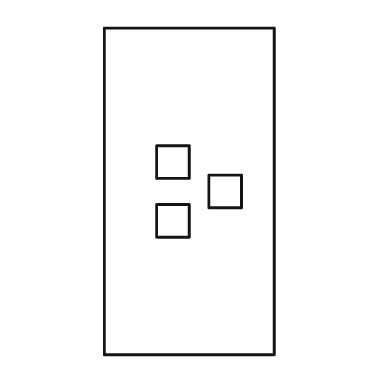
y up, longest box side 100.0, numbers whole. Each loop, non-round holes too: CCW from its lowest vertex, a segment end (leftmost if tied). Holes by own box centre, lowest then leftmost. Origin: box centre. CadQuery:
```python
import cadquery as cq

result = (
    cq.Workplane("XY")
    .moveTo(-26.0, -50.0)
    .lineTo(26.0, -50.0)
    .lineTo(26.0, 50.0)
    .lineTo(-26.0, 50.0)
    .close()
    .moveTo(-10.0, -14.0)
    .lineTo(0.0, -14.0)
    .lineTo(0.0, -4.0)
    .lineTo(-10.0, -4.0)
    .close()
    .moveTo(6.0, -5.0)
    .lineTo(16.0, -5.0)
    .lineTo(16.0, 5.0)
    .lineTo(6.0, 5.0)
    .close()
    .moveTo(-10.0, 4.0)
    .lineTo(0.0, 4.0)
    .lineTo(0.0, 14.0)
    .lineTo(-10.0, 14.0)
    .close()
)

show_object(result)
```